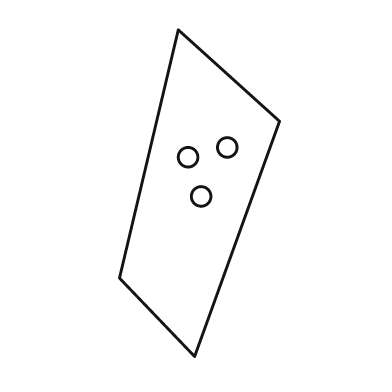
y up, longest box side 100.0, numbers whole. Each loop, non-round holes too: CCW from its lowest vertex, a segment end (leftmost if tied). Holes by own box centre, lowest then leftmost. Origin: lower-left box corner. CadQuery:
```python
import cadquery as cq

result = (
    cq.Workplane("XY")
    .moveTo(23.0, 0.0)
    .lineTo(49.0, 72.0)
    .lineTo(18.0, 100.0)
    .lineTo(0.0, 24.0)
    .close()
    .moveTo(25.0, 49.0)
    .circle(3.0)
    .moveTo(21.0, 61.0)
    .circle(3.0)
    .moveTo(33.0, 64.0)
    .circle(3.0)
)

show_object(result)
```